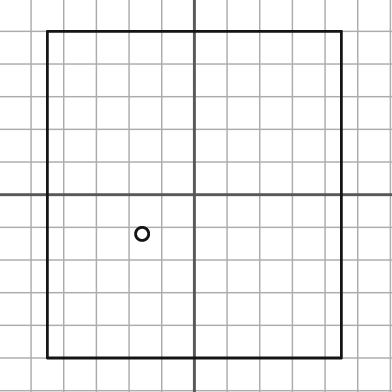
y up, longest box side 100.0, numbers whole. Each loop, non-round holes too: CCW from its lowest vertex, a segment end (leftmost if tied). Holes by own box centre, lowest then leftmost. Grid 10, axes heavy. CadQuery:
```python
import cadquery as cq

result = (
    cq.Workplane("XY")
    .moveTo(-45.0, -50.0)
    .lineTo(45.0, -50.0)
    .lineTo(45.0, 50.0)
    .lineTo(-45.0, 50.0)
    .close()
    .moveTo(-16.0, -12.0)
    .circle(2.0)
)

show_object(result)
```